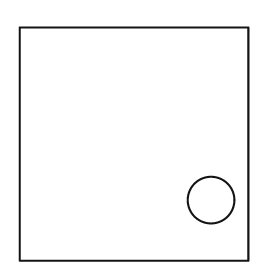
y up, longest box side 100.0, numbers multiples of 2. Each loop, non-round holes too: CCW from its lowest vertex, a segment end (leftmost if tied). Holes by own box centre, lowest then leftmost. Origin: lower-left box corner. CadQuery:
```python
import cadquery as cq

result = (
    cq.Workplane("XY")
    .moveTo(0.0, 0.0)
    .lineTo(98.0, 0.0)
    .lineTo(98.0, 100.0)
    .lineTo(0.0, 100.0)
    .close()
    .moveTo(82.0, 26.0)
    .circle(10.0)
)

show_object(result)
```